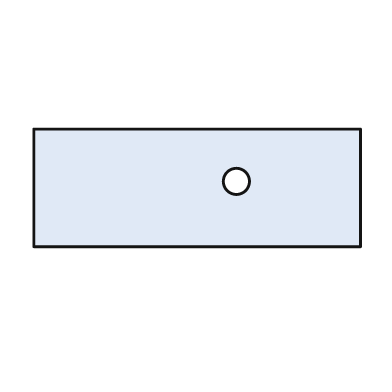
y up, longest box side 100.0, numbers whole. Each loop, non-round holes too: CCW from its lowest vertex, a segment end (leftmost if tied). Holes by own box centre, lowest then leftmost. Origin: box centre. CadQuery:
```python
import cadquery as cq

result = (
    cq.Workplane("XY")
    .moveTo(-50.0, -18.0)
    .lineTo(50.0, -18.0)
    .lineTo(50.0, 18.0)
    .lineTo(-50.0, 18.0)
    .close()
    .moveTo(12.0, 2.0)
    .circle(4.0)
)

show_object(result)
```